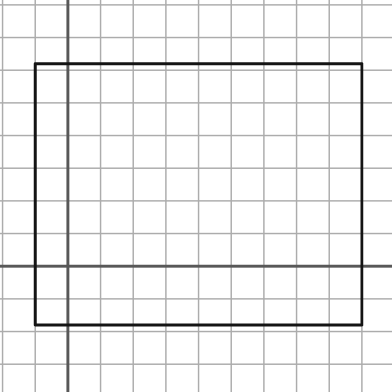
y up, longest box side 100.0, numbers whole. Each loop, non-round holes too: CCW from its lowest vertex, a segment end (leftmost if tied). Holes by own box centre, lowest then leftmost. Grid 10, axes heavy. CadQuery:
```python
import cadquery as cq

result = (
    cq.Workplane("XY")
    .moveTo(-10.0, -18.0)
    .lineTo(90.0, -18.0)
    .lineTo(90.0, 62.0)
    .lineTo(-10.0, 62.0)
    .close()
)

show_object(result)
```